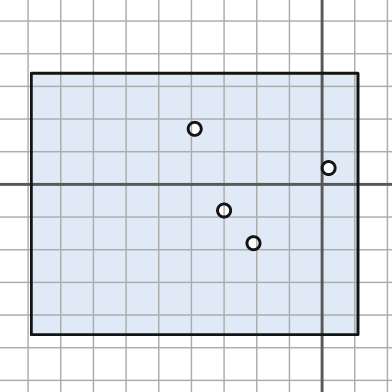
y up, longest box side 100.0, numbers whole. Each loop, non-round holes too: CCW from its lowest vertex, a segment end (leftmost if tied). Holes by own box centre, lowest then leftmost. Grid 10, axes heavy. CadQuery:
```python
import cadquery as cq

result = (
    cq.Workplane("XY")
    .moveTo(-89.0, -46.0)
    .lineTo(11.0, -46.0)
    .lineTo(11.0, 34.0)
    .lineTo(-89.0, 34.0)
    .close()
    .moveTo(-21.0, -18.0)
    .circle(2.0)
    .moveTo(-30.0, -8.0)
    .circle(2.0)
    .moveTo(2.0, 5.0)
    .circle(2.0)
    .moveTo(-39.0, 17.0)
    .circle(2.0)
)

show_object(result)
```